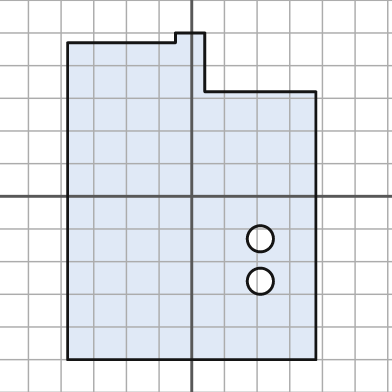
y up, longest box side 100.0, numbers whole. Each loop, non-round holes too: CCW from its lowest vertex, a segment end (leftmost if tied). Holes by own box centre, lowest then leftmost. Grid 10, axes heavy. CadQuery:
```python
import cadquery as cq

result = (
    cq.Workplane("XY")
    .moveTo(-38.0, -50.0)
    .lineTo(38.0, -50.0)
    .lineTo(38.0, 32.0)
    .lineTo(4.0, 32.0)
    .lineTo(4.0, 50.0)
    .lineTo(-5.0, 50.0)
    .lineTo(-5.0, 47.0)
    .lineTo(-38.0, 47.0)
    .close()
    .moveTo(21.0, -26.0)
    .circle(4.0)
    .moveTo(21.0, -13.0)
    .circle(4.0)
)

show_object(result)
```